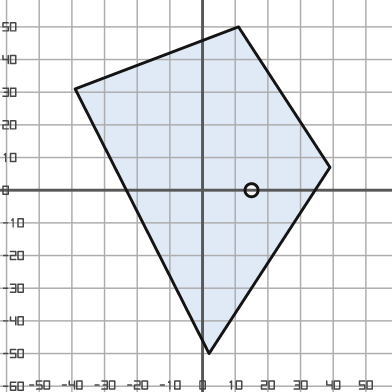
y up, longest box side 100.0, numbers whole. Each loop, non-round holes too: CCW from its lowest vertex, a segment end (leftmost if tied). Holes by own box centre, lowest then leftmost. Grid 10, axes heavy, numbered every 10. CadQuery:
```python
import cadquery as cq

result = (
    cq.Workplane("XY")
    .moveTo(2.0, -50.0)
    .lineTo(39.0, 7.0)
    .lineTo(11.0, 50.0)
    .lineTo(-39.0, 31.0)
    .close()
    .moveTo(15.0, 0.0)
    .circle(2.0)
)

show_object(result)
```